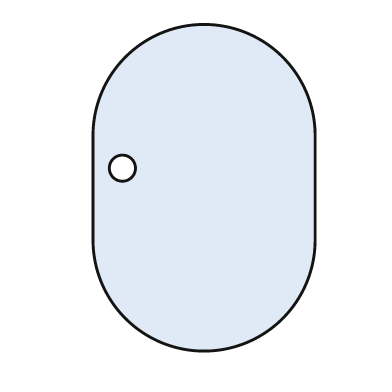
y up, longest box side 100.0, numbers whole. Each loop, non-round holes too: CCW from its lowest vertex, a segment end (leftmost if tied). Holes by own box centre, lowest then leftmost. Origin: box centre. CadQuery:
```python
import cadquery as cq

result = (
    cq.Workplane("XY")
    .moveTo(-34.0, -16.0)
    .threePointArc((0.0, -50.0), (34.0, -16.0))
    .lineTo(34.0, 16.0)
    .threePointArc((0.0, 50.0), (-34.0, 16.0))
    .close()
    .moveTo(-25.0, 6.0)
    .circle(4.0)
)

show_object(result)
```